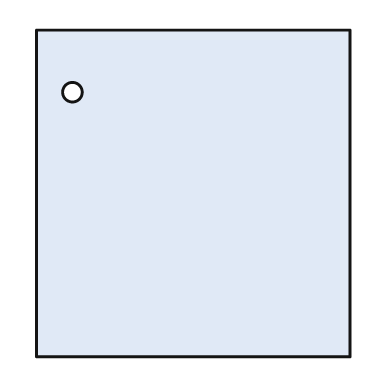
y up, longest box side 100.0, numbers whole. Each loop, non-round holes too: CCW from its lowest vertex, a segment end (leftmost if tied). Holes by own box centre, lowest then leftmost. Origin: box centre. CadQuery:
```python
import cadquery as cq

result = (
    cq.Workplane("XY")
    .moveTo(-48.0, -50.0)
    .lineTo(48.0, -50.0)
    .lineTo(48.0, 50.0)
    .lineTo(-48.0, 50.0)
    .close()
    .moveTo(-37.0, 31.0)
    .circle(3.0)
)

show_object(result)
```